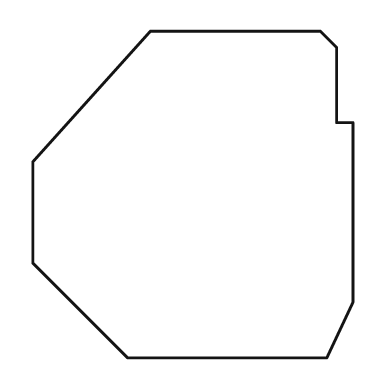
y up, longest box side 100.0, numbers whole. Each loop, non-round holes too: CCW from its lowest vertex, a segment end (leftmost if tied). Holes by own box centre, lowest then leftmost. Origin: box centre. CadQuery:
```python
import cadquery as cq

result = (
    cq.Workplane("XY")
    .moveTo(-20.0, -50.0)
    .lineTo(41.0, -50.0)
    .lineTo(49.0, -33.0)
    .lineTo(49.0, 22.0)
    .lineTo(44.0, 22.0)
    .lineTo(44.0, 45.0)
    .lineTo(39.0, 50.0)
    .lineTo(-13.0, 50.0)
    .lineTo(-49.0, 10.0)
    .lineTo(-49.0, -21.0)
    .close()
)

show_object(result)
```